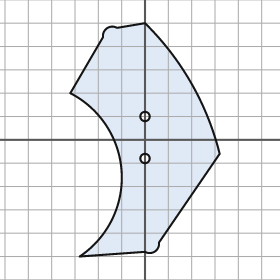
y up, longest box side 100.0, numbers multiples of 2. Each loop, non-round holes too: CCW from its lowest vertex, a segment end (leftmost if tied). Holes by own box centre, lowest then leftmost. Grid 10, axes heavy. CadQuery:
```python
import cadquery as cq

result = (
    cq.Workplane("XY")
    .moveTo(-28.0, -50.0)
    .lineTo(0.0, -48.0)
    .threePointArc((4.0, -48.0), (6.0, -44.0))
    .lineTo(32.0, -6.0)
    .threePointArc((20.0, 24.0), (0.0, 50.0))
    .lineTo(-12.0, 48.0)
    .threePointArc((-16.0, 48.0), (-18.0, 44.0))
    .lineTo(-32.0, 20.0)
    .threePointArc((-10.0, -14.0), (-28.0, -50.0))
    .close()
    .moveTo(0.0, -8.0)
    .circle(2.0)
    .moveTo(0.0, 10.0)
    .circle(2.0)
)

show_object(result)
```